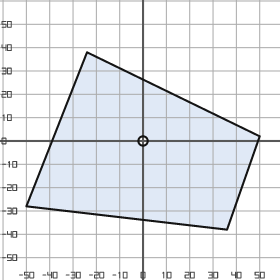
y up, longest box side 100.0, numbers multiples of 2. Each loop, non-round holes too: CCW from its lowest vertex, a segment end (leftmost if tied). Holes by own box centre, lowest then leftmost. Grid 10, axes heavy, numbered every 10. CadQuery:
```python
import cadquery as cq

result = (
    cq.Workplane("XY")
    .moveTo(36.0, -38.0)
    .lineTo(50.0, 2.0)
    .lineTo(-24.0, 38.0)
    .lineTo(-50.0, -28.0)
    .close()
    .moveTo(0.0, 0.0)
    .circle(2.0)
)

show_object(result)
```